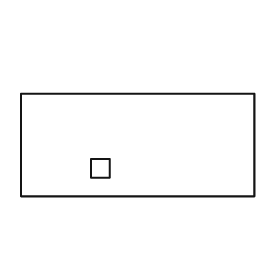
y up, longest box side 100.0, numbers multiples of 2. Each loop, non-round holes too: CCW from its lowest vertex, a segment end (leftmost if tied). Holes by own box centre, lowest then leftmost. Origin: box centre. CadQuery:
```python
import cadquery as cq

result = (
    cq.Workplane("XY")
    .moveTo(-50.0, -22.0)
    .lineTo(50.0, -22.0)
    .lineTo(50.0, 22.0)
    .lineTo(-50.0, 22.0)
    .close()
    .moveTo(-20.0, -14.0)
    .lineTo(-12.0, -14.0)
    .lineTo(-12.0, -6.0)
    .lineTo(-20.0, -6.0)
    .close()
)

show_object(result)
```